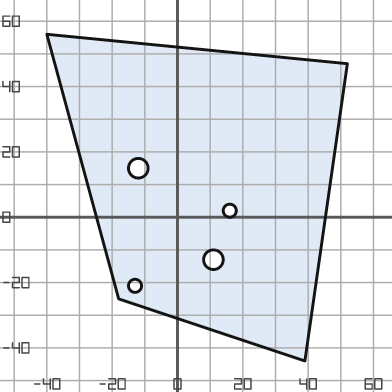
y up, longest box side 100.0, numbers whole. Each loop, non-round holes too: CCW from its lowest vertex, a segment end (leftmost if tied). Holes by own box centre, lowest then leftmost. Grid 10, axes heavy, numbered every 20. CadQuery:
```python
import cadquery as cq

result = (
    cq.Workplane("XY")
    .moveTo(39.0, -44.0)
    .lineTo(52.0, 47.0)
    .lineTo(-40.0, 56.0)
    .lineTo(-18.0, -25.0)
    .close()
    .moveTo(-13.0, -21.0)
    .circle(2.0)
    .moveTo(11.0, -13.0)
    .circle(3.0)
    .moveTo(16.0, 2.0)
    .circle(2.0)
    .moveTo(-12.0, 15.0)
    .circle(3.0)
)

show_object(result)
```